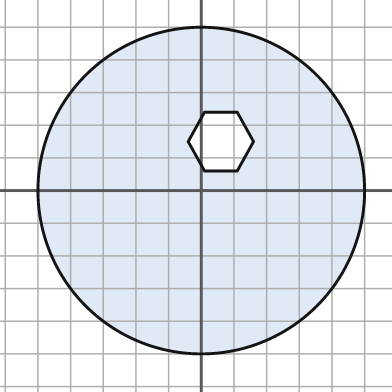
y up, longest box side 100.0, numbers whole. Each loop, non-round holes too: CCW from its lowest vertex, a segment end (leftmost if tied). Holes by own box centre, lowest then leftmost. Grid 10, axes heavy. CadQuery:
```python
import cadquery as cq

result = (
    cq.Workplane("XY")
    .moveTo(0.0, 0.0)
    .circle(50.0)
    .moveTo(1.0, 6.0)
    .lineTo(11.0, 6.0)
    .lineTo(16.0, 15.0)
    .lineTo(11.0, 24.0)
    .lineTo(1.0, 24.0)
    .lineTo(-4.0, 15.0)
    .close()
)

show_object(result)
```